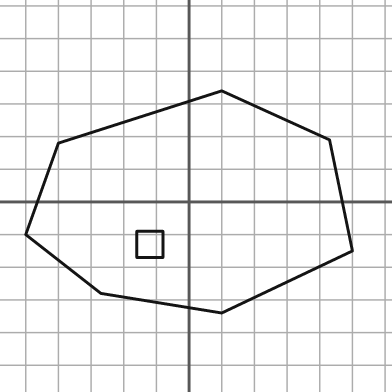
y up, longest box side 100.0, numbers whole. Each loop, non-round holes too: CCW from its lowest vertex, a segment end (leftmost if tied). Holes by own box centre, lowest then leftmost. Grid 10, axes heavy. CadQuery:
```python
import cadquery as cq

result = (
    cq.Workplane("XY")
    .moveTo(10.0, -34.0)
    .lineTo(50.0, -15.0)
    .lineTo(43.0, 19.0)
    .lineTo(10.0, 34.0)
    .lineTo(-40.0, 18.0)
    .lineTo(-50.0, -10.0)
    .lineTo(-27.0, -28.0)
    .close()
    .moveTo(-16.0, -17.0)
    .lineTo(-8.0, -17.0)
    .lineTo(-8.0, -9.0)
    .lineTo(-16.0, -9.0)
    .close()
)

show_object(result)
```